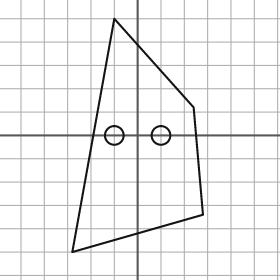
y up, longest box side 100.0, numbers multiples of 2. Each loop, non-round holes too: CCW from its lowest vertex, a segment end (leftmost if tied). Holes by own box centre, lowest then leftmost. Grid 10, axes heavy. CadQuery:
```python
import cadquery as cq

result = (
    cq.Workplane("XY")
    .moveTo(-28.0, -50.0)
    .lineTo(28.0, -34.0)
    .lineTo(24.0, 12.0)
    .lineTo(-10.0, 50.0)
    .close()
    .moveTo(-10.0, 0.0)
    .circle(4.0)
    .moveTo(10.0, 0.0)
    .circle(4.0)
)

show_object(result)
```